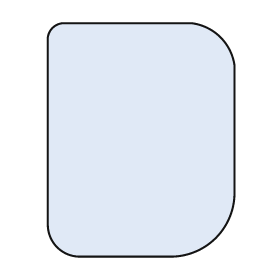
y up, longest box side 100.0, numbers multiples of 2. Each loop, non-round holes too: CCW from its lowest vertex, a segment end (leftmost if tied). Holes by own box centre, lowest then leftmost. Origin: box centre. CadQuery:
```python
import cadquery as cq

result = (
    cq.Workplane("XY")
    .moveTo(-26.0, -50.0)
    .lineTo(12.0, -50.0)
    .threePointArc((32.0, -42.0), (40.0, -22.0))
    .lineTo(40.0, 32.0)
    .threePointArc((34.0, 44.0), (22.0, 50.0))
    .lineTo(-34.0, 50.0)
    .threePointArc((-38.0, 48.0), (-40.0, 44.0))
    .lineTo(-40.0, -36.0)
    .threePointArc((-36.0, -46.0), (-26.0, -50.0))
    .close()
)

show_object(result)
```